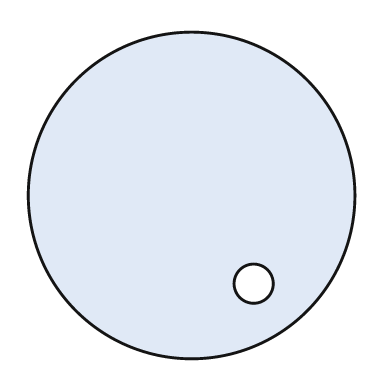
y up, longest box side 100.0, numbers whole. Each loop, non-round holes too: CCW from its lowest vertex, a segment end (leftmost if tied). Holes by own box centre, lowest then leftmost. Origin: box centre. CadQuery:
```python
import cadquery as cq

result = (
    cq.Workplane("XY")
    .moveTo(0.0, 0.0)
    .circle(50.0)
    .moveTo(19.0, -27.0)
    .circle(6.0)
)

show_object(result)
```